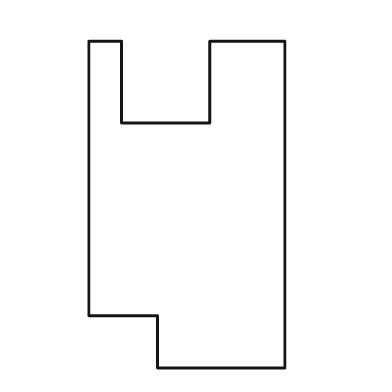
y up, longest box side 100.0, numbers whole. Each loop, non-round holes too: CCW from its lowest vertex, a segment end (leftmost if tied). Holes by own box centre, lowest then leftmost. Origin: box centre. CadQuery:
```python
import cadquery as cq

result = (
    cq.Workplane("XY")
    .moveTo(-9.0, -50.0)
    .lineTo(30.0, -50.0)
    .lineTo(30.0, 50.0)
    .lineTo(7.0, 50.0)
    .lineTo(7.0, 25.0)
    .lineTo(-20.0, 25.0)
    .lineTo(-20.0, 50.0)
    .lineTo(-30.0, 50.0)
    .lineTo(-30.0, -34.0)
    .lineTo(-9.0, -34.0)
    .close()
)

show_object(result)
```